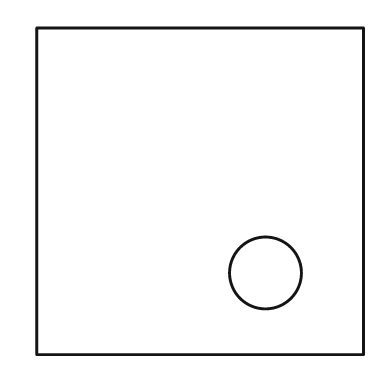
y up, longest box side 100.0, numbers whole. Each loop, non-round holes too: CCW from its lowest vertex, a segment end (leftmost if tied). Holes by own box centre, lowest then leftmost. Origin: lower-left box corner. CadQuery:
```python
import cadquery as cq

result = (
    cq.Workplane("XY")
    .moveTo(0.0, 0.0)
    .lineTo(100.0, 0.0)
    .lineTo(100.0, 100.0)
    .lineTo(0.0, 100.0)
    .close()
    .moveTo(70.0, 25.0)
    .circle(11.0)
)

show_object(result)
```